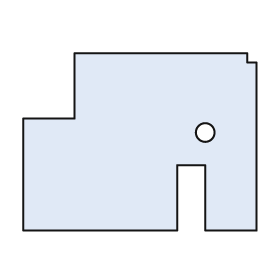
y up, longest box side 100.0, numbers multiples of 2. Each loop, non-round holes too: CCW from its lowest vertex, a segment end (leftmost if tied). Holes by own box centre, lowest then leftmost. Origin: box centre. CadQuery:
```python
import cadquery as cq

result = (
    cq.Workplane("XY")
    .moveTo(-50.0, -38.0)
    .lineTo(16.0, -38.0)
    .lineTo(16.0, -10.0)
    .lineTo(28.0, -10.0)
    .lineTo(28.0, -38.0)
    .lineTo(50.0, -38.0)
    .lineTo(50.0, 34.0)
    .lineTo(46.0, 34.0)
    .lineTo(46.0, 38.0)
    .lineTo(-28.0, 38.0)
    .lineTo(-28.0, 10.0)
    .lineTo(-50.0, 10.0)
    .close()
    .moveTo(28.0, 4.0)
    .circle(4.0)
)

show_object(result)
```